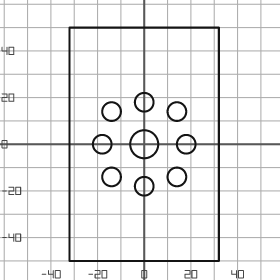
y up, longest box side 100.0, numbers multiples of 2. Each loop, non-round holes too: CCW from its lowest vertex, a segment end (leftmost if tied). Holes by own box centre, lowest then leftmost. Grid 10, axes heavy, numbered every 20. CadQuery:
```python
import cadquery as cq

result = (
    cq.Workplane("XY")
    .moveTo(-32.0, -50.0)
    .lineTo(32.0, -50.0)
    .lineTo(32.0, 50.0)
    .lineTo(-32.0, 50.0)
    .close()
    .moveTo(0.0, -18.0)
    .circle(4.0)
    .moveTo(-14.0, -14.0)
    .circle(4.0)
    .moveTo(14.0, -14.0)
    .circle(4.0)
    .moveTo(-18.0, 0.0)
    .circle(4.0)
    .moveTo(0.0, 0.0)
    .circle(6.0)
    .moveTo(18.0, 0.0)
    .circle(4.0)
    .moveTo(-14.0, 14.0)
    .circle(4.0)
    .moveTo(14.0, 14.0)
    .circle(4.0)
    .moveTo(0.0, 18.0)
    .circle(4.0)
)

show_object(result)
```